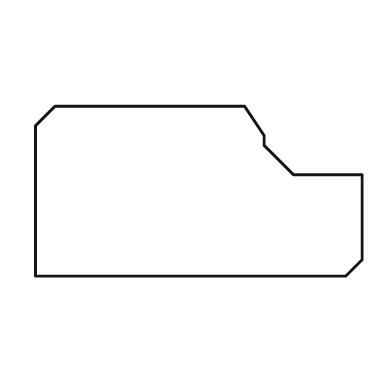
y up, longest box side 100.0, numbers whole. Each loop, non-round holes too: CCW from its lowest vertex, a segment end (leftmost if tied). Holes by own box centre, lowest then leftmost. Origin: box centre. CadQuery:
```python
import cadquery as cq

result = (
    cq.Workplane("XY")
    .moveTo(-50.0, -26.0)
    .lineTo(45.0, -26.0)
    .lineTo(50.0, -21.0)
    .lineTo(50.0, 5.0)
    .lineTo(29.0, 5.0)
    .lineTo(20.0, 14.0)
    .lineTo(20.0, 17.0)
    .lineTo(14.0, 26.0)
    .lineTo(-44.0, 26.0)
    .lineTo(-50.0, 20.0)
    .close()
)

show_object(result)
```